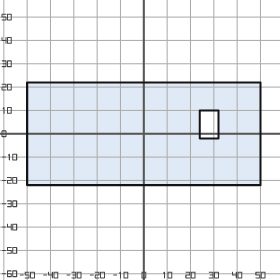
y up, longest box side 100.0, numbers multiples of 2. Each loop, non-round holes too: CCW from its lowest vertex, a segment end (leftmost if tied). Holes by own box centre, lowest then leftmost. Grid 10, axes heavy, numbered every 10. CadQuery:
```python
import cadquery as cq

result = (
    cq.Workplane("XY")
    .moveTo(-50.0, -22.0)
    .lineTo(50.0, -22.0)
    .lineTo(50.0, 22.0)
    .lineTo(-50.0, 22.0)
    .close()
    .moveTo(24.0, -2.0)
    .lineTo(32.0, -2.0)
    .lineTo(32.0, 10.0)
    .lineTo(24.0, 10.0)
    .close()
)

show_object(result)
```